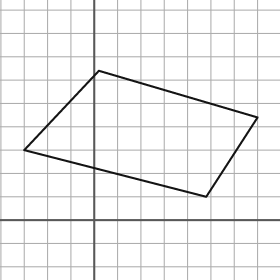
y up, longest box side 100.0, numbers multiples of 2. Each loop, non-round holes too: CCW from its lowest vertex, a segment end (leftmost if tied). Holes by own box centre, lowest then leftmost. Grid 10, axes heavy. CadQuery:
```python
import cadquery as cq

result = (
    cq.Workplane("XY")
    .moveTo(48.0, 10.0)
    .lineTo(70.0, 44.0)
    .lineTo(2.0, 64.0)
    .lineTo(-30.0, 30.0)
    .close()
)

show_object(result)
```